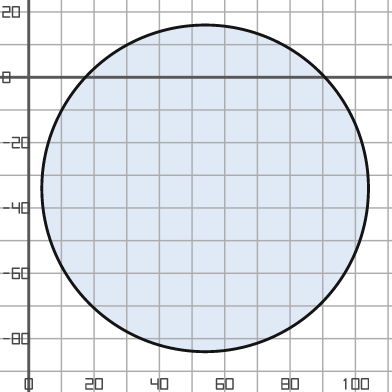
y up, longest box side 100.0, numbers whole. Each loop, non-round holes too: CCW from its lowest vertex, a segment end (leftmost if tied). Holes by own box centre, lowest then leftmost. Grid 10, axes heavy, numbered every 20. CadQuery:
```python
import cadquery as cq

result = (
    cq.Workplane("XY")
    .moveTo(54.0, -34.0)
    .circle(50.0)
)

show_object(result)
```